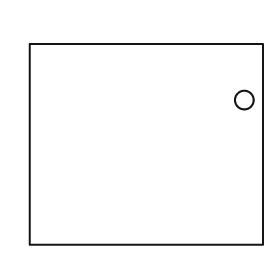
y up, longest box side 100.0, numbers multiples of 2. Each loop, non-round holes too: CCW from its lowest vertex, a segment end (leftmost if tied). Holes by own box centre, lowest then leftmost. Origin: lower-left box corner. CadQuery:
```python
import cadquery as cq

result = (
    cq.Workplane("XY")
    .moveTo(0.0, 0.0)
    .lineTo(100.0, 0.0)
    .lineTo(100.0, 86.0)
    .lineTo(0.0, 86.0)
    .close()
    .moveTo(92.0, 62.0)
    .circle(4.0)
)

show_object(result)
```